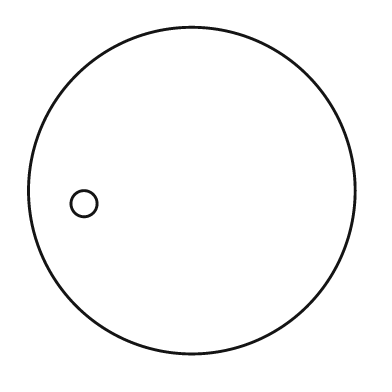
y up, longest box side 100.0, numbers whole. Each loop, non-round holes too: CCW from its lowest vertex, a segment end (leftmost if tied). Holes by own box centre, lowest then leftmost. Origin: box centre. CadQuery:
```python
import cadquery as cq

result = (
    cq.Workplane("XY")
    .moveTo(0.0, 0.0)
    .circle(50.0)
    .moveTo(-33.0, -4.0)
    .circle(4.0)
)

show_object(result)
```